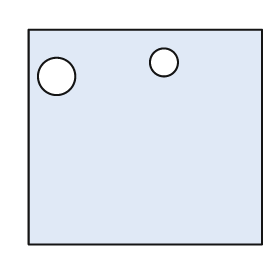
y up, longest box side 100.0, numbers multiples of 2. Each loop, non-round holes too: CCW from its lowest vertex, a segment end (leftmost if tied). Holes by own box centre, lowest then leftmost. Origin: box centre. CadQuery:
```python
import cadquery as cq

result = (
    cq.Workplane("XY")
    .moveTo(-50.0, -46.0)
    .lineTo(50.0, -46.0)
    .lineTo(50.0, 46.0)
    .lineTo(-50.0, 46.0)
    .close()
    .moveTo(-38.0, 26.0)
    .circle(8.0)
    .moveTo(8.0, 32.0)
    .circle(6.0)
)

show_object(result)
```